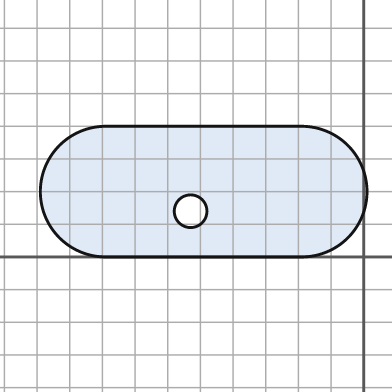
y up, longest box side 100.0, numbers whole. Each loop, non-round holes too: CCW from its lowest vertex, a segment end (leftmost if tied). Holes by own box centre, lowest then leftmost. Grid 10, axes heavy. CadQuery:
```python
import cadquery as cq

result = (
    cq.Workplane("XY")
    .moveTo(-79.0, 0.0)
    .lineTo(-19.0, 0.0)
    .threePointArc((1.0, 20.0), (-19.0, 40.0))
    .lineTo(-79.0, 40.0)
    .threePointArc((-99.0, 20.0), (-79.0, 0.0))
    .close()
    .moveTo(-53.0, 14.0)
    .circle(5.0)
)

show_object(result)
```